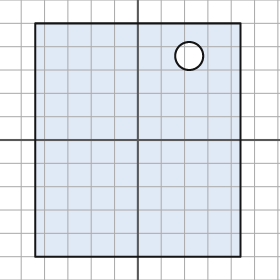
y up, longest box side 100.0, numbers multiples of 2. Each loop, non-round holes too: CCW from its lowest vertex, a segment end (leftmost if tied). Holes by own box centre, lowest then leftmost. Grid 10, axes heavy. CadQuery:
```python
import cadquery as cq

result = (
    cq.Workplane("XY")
    .moveTo(-44.0, -50.0)
    .lineTo(44.0, -50.0)
    .lineTo(44.0, 50.0)
    .lineTo(-44.0, 50.0)
    .close()
    .moveTo(22.0, 36.0)
    .circle(6.0)
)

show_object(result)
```